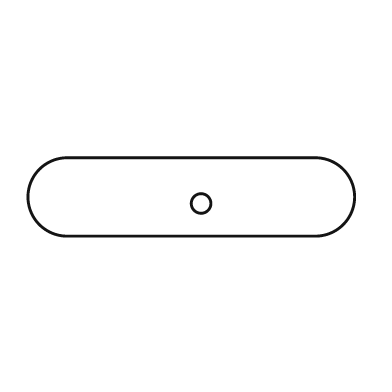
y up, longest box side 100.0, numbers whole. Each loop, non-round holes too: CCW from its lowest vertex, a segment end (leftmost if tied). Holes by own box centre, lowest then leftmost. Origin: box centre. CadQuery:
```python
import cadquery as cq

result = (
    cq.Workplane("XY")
    .moveTo(-38.0, -12.0)
    .lineTo(38.0, -12.0)
    .threePointArc((50.0, 0.0), (38.0, 12.0))
    .lineTo(-38.0, 12.0)
    .threePointArc((-50.0, 0.0), (-38.0, -12.0))
    .close()
    .moveTo(3.0, -2.0)
    .circle(3.0)
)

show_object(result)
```